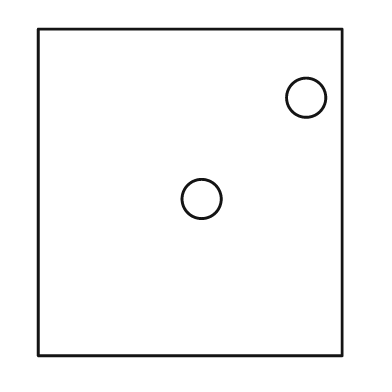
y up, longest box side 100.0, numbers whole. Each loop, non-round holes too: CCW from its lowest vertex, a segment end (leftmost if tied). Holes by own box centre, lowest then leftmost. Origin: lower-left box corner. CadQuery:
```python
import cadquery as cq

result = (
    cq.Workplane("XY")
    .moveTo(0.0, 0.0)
    .lineTo(93.0, 0.0)
    .lineTo(93.0, 100.0)
    .lineTo(0.0, 100.0)
    .close()
    .moveTo(50.0, 48.0)
    .circle(6.0)
    .moveTo(82.0, 79.0)
    .circle(6.0)
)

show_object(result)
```